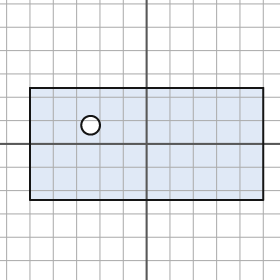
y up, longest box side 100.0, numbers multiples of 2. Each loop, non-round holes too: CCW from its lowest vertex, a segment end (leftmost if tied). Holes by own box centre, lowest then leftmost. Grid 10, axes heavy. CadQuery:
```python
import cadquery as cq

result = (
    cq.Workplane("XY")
    .moveTo(-50.0, -24.0)
    .lineTo(50.0, -24.0)
    .lineTo(50.0, 24.0)
    .lineTo(-50.0, 24.0)
    .close()
    .moveTo(-24.0, 8.0)
    .circle(4.0)
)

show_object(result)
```